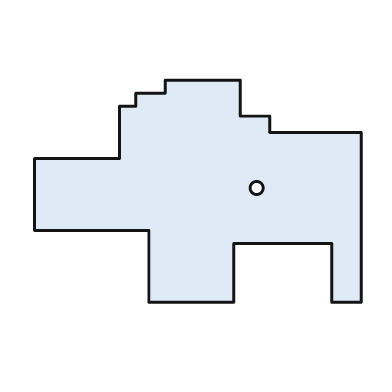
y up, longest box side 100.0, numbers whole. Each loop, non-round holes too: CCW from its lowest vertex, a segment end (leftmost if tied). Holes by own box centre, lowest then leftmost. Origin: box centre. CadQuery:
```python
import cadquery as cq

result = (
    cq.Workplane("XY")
    .moveTo(-15.0, -34.0)
    .lineTo(11.0, -34.0)
    .lineTo(11.0, -16.0)
    .lineTo(41.0, -16.0)
    .lineTo(41.0, -34.0)
    .lineTo(50.0, -34.0)
    .lineTo(50.0, 18.0)
    .lineTo(22.0, 18.0)
    .lineTo(22.0, 23.0)
    .lineTo(13.0, 23.0)
    .lineTo(13.0, 34.0)
    .lineTo(-10.0, 34.0)
    .lineTo(-10.0, 30.0)
    .lineTo(-19.0, 30.0)
    .lineTo(-19.0, 26.0)
    .lineTo(-24.0, 26.0)
    .lineTo(-24.0, 10.0)
    .lineTo(-50.0, 10.0)
    .lineTo(-50.0, -12.0)
    .lineTo(-15.0, -12.0)
    .close()
    .moveTo(18.0, 1.0)
    .circle(2.0)
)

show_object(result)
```